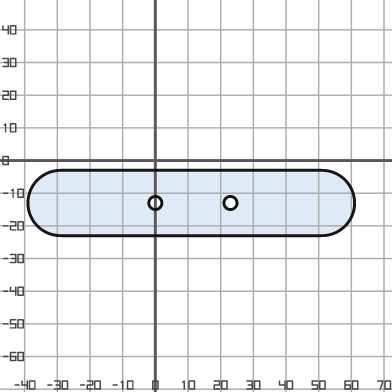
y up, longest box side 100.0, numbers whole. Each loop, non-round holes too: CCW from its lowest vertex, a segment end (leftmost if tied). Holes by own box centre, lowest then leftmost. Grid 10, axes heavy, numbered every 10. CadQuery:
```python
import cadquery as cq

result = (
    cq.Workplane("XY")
    .moveTo(-29.0, -23.0)
    .lineTo(51.0, -23.0)
    .threePointArc((61.0, -13.0), (51.0, -3.0))
    .lineTo(-29.0, -3.0)
    .threePointArc((-39.0, -13.0), (-29.0, -23.0))
    .close()
    .moveTo(0.0, -13.0)
    .circle(2.0)
    .moveTo(23.0, -13.0)
    .circle(2.0)
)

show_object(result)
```